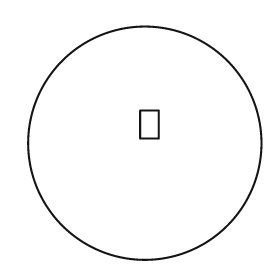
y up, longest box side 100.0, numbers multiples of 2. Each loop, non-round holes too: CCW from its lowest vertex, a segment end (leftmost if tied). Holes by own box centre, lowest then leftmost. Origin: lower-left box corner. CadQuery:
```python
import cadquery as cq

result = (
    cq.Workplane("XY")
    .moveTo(50.0, 50.0)
    .circle(50.0)
    .moveTo(48.0, 52.0)
    .lineTo(56.0, 52.0)
    .lineTo(56.0, 64.0)
    .lineTo(48.0, 64.0)
    .close()
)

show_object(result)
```